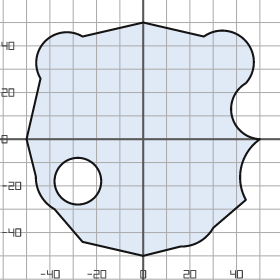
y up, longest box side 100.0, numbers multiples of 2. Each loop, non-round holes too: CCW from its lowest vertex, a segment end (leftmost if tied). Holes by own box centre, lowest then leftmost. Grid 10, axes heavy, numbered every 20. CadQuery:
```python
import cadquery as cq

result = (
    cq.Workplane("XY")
    .moveTo(0.0, -50.0)
    .lineTo(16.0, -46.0)
    .threePointArc((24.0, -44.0), (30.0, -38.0))
    .lineTo(44.0, -26.0)
    .threePointArc((42.0, -12.0), (50.0, 0.0))
    .threePointArc((38.0, 10.0), (44.0, 24.0))
    .threePointArc((44.0, 42.0), (26.0, 44.0))
    .lineTo(0.0, 50.0)
    .lineTo(-26.0, 44.0)
    .threePointArc((-42.0, 42.0), (-44.0, 26.0))
    .lineTo(-50.0, 0.0)
    .lineTo(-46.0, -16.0)
    .threePointArc((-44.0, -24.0), (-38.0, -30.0))
    .lineTo(-26.0, -44.0)
    .close()
    .moveTo(-28.0, -18.0)
    .circle(10.0)
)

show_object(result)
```